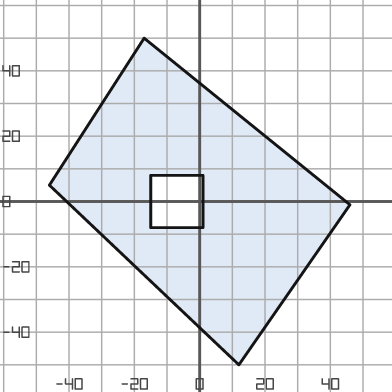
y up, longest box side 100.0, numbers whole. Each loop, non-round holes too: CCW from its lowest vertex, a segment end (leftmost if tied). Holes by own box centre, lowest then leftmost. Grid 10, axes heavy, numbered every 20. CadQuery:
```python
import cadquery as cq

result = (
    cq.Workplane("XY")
    .moveTo(12.0, -50.0)
    .lineTo(46.0, -1.0)
    .lineTo(-17.0, 50.0)
    .lineTo(-46.0, 5.0)
    .close()
    .moveTo(-15.0, -8.0)
    .lineTo(1.0, -8.0)
    .lineTo(1.0, 8.0)
    .lineTo(-15.0, 8.0)
    .close()
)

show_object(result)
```